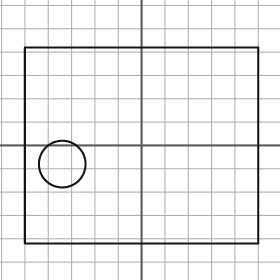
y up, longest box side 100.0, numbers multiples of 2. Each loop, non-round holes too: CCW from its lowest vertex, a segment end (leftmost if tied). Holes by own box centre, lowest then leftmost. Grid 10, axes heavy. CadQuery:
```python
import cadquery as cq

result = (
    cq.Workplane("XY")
    .moveTo(-50.0, -42.0)
    .lineTo(50.0, -42.0)
    .lineTo(50.0, 42.0)
    .lineTo(-50.0, 42.0)
    .close()
    .moveTo(-34.0, -8.0)
    .circle(10.0)
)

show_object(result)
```